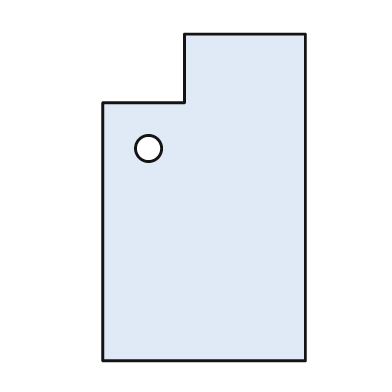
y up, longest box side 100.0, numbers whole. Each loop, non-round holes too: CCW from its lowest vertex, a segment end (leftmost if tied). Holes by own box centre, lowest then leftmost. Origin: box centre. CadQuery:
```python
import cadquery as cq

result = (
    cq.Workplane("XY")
    .moveTo(-31.0, -50.0)
    .lineTo(31.0, -50.0)
    .lineTo(31.0, 50.0)
    .lineTo(-6.0, 50.0)
    .lineTo(-6.0, 29.0)
    .lineTo(-31.0, 29.0)
    .close()
    .moveTo(-17.0, 15.0)
    .circle(4.0)
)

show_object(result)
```